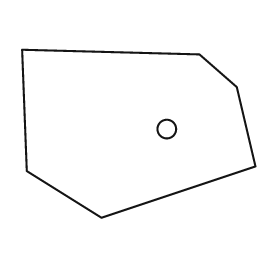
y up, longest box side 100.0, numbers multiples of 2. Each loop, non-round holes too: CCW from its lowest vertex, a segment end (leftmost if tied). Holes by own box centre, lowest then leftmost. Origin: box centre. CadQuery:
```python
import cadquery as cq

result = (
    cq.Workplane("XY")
    .moveTo(-16.0, -36.0)
    .lineTo(50.0, -14.0)
    .lineTo(42.0, 20.0)
    .lineTo(26.0, 34.0)
    .lineTo(-50.0, 36.0)
    .lineTo(-48.0, -16.0)
    .close()
    .moveTo(12.0, 2.0)
    .circle(4.0)
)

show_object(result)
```